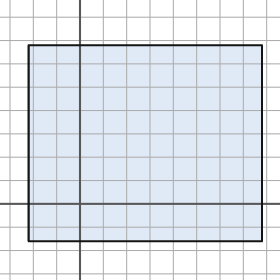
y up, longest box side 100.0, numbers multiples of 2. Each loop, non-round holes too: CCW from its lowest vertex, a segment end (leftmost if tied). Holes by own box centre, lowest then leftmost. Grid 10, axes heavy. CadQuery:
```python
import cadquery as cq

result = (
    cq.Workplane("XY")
    .moveTo(-22.0, -16.0)
    .lineTo(78.0, -16.0)
    .lineTo(78.0, 68.0)
    .lineTo(-22.0, 68.0)
    .close()
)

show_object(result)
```